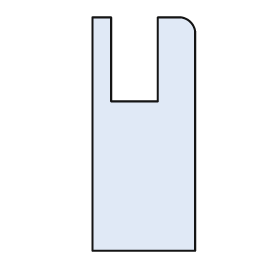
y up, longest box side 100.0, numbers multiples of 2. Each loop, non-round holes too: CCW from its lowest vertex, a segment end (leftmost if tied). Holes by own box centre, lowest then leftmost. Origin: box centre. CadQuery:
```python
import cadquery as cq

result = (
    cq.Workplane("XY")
    .moveTo(-22.0, -50.0)
    .lineTo(22.0, -50.0)
    .lineTo(22.0, 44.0)
    .threePointArc((20.0, 48.0), (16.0, 50.0))
    .lineTo(6.0, 50.0)
    .lineTo(6.0, 14.0)
    .lineTo(-14.0, 14.0)
    .lineTo(-14.0, 50.0)
    .lineTo(-22.0, 50.0)
    .close()
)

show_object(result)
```